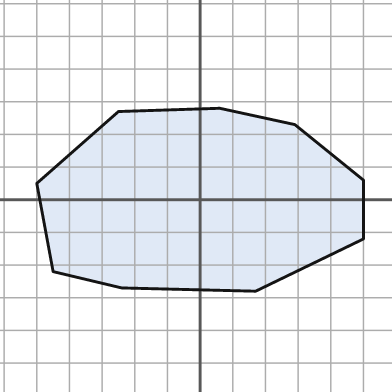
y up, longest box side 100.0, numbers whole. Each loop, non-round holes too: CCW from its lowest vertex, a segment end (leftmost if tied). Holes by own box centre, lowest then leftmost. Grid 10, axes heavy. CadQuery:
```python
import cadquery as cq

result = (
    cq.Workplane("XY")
    .moveTo(17.0, -28.0)
    .lineTo(50.0, -12.0)
    .lineTo(50.0, 6.0)
    .lineTo(29.0, 23.0)
    .lineTo(6.0, 28.0)
    .lineTo(-25.0, 27.0)
    .lineTo(-50.0, 5.0)
    .lineTo(-45.0, -22.0)
    .lineTo(-24.0, -27.0)
    .close()
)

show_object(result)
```